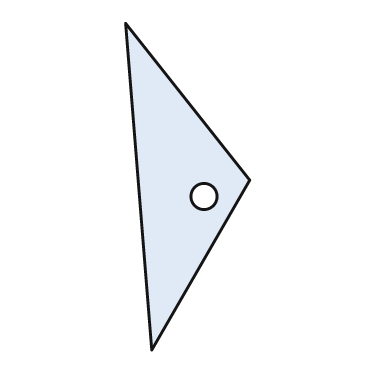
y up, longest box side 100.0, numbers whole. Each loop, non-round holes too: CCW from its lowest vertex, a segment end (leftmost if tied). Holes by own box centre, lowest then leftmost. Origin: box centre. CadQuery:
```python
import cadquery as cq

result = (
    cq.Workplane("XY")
    .moveTo(-11.0, -50.0)
    .lineTo(19.0, 2.0)
    .lineTo(-19.0, 50.0)
    .close()
    .moveTo(5.0, -3.0)
    .circle(4.0)
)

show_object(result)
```